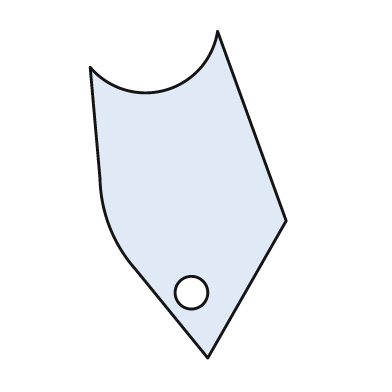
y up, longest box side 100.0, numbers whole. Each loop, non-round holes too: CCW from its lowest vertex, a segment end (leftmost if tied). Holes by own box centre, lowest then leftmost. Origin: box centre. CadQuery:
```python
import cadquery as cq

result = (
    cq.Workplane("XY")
    .moveTo(6.0, -50.0)
    .lineTo(30.0, -8.0)
    .lineTo(9.0, 50.0)
    .threePointArc((-7.0, 32.0), (-30.0, 39.0))
    .lineTo(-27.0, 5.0)
    .threePointArc((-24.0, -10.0), (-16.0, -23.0))
    .close()
    .moveTo(1.0, -30.0)
    .circle(5.0)
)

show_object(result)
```